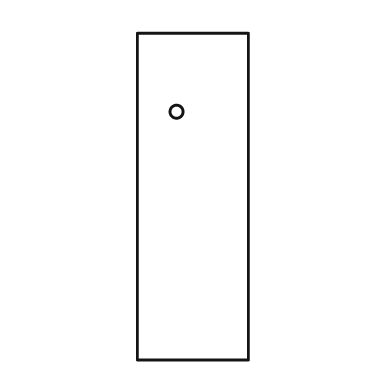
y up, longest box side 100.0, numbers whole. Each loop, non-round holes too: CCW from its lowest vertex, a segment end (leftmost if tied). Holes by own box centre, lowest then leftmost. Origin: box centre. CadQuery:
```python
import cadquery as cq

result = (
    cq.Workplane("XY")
    .moveTo(-17.0, -50.0)
    .lineTo(17.0, -50.0)
    .lineTo(17.0, 50.0)
    .lineTo(-17.0, 50.0)
    .close()
    .moveTo(-5.0, 26.0)
    .circle(2.0)
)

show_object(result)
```